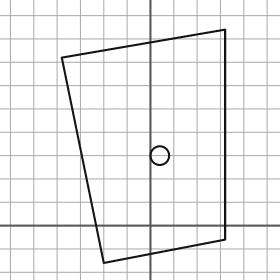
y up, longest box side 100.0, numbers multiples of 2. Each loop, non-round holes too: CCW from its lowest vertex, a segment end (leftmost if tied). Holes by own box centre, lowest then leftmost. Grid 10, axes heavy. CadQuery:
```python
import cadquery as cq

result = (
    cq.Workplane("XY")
    .moveTo(-20.0, -16.0)
    .lineTo(32.0, -6.0)
    .lineTo(32.0, 84.0)
    .lineTo(-38.0, 72.0)
    .close()
    .moveTo(4.0, 30.0)
    .circle(4.0)
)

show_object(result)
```